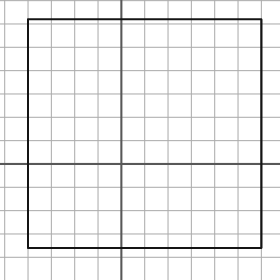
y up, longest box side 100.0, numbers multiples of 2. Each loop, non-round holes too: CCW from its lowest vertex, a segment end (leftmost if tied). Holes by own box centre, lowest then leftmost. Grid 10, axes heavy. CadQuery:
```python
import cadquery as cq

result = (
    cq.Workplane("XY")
    .moveTo(-40.0, -36.0)
    .lineTo(60.0, -36.0)
    .lineTo(60.0, 62.0)
    .lineTo(-40.0, 62.0)
    .close()
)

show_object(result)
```